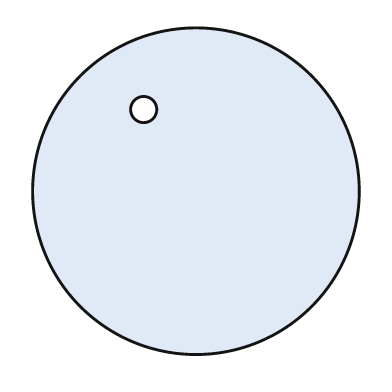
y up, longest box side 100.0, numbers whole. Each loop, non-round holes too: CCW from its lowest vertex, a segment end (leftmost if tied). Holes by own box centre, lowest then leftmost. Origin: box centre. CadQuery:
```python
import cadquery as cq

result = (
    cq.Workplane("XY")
    .moveTo(0.0, 0.0)
    .circle(50.0)
    .moveTo(-16.0, 25.0)
    .circle(4.0)
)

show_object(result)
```